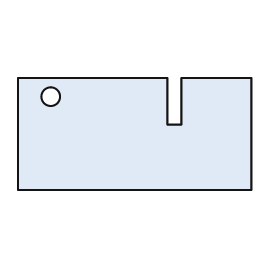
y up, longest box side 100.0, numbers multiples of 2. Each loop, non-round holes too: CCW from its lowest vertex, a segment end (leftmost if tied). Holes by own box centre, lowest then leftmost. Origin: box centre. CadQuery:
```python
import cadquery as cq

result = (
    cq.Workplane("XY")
    .moveTo(-50.0, -24.0)
    .lineTo(50.0, -24.0)
    .lineTo(50.0, 24.0)
    .lineTo(20.0, 24.0)
    .lineTo(20.0, 4.0)
    .lineTo(14.0, 4.0)
    .lineTo(14.0, 24.0)
    .lineTo(-50.0, 24.0)
    .close()
    .moveTo(-36.0, 16.0)
    .circle(4.0)
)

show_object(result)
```